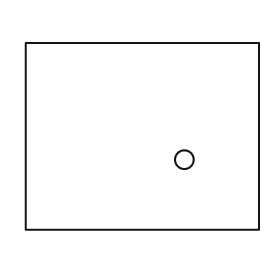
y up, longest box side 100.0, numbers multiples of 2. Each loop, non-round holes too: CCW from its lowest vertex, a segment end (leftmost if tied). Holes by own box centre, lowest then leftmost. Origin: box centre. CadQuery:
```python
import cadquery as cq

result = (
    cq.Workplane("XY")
    .moveTo(-50.0, -40.0)
    .lineTo(50.0, -40.0)
    .lineTo(50.0, 40.0)
    .lineTo(-50.0, 40.0)
    .close()
    .moveTo(18.0, -10.0)
    .circle(4.0)
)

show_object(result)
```